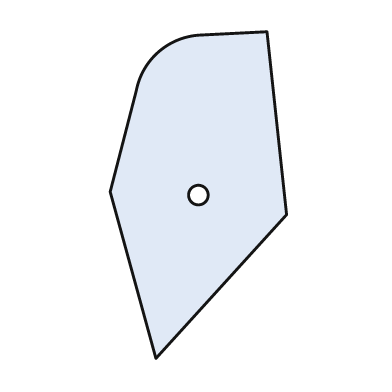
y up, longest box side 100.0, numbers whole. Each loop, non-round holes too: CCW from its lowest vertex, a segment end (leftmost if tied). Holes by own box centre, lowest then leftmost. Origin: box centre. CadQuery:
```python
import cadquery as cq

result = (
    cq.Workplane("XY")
    .moveTo(-13.0, -50.0)
    .lineTo(27.0, -6.0)
    .lineTo(21.0, 50.0)
    .lineTo(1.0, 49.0)
    .threePointArc((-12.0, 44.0), (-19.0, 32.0))
    .lineTo(-27.0, 1.0)
    .close()
    .moveTo(0.0, 0.0)
    .circle(3.0)
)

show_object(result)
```